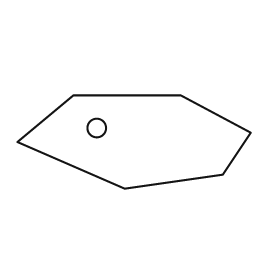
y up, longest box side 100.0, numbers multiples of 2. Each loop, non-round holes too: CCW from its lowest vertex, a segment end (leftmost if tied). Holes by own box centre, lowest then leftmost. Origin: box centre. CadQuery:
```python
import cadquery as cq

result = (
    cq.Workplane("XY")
    .moveTo(-4.0, -20.0)
    .lineTo(38.0, -14.0)
    .lineTo(50.0, 4.0)
    .lineTo(20.0, 20.0)
    .lineTo(-26.0, 20.0)
    .lineTo(-50.0, 0.0)
    .close()
    .moveTo(-16.0, 6.0)
    .circle(4.0)
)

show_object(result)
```